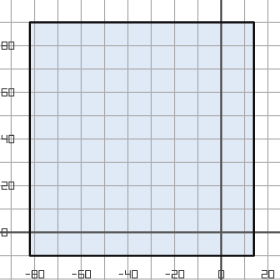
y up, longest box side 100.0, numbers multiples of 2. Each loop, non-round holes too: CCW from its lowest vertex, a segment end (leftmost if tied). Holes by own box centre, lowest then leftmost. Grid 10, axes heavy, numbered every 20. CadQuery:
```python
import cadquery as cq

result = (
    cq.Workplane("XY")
    .moveTo(-82.0, -10.0)
    .lineTo(14.0, -10.0)
    .lineTo(14.0, 90.0)
    .lineTo(-82.0, 90.0)
    .close()
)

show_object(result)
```